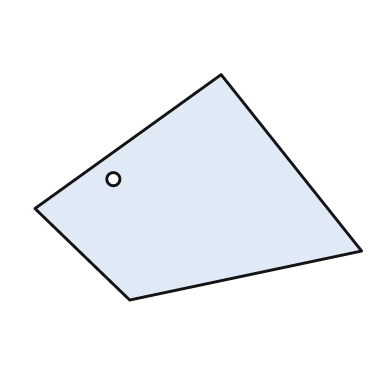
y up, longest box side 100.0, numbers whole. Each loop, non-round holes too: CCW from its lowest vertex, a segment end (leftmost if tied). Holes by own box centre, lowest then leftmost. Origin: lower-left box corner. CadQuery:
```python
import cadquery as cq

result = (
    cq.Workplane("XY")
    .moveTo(29.0, 0.0)
    .lineTo(100.0, 15.0)
    .lineTo(57.0, 69.0)
    .lineTo(0.0, 28.0)
    .close()
    .moveTo(24.0, 37.0)
    .circle(2.0)
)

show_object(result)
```